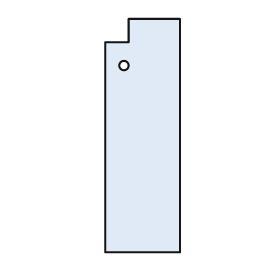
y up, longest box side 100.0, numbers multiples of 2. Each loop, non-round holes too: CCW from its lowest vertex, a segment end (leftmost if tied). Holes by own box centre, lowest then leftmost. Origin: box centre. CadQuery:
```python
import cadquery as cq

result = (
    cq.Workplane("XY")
    .moveTo(-16.0, -50.0)
    .lineTo(16.0, -50.0)
    .lineTo(16.0, 50.0)
    .lineTo(-6.0, 50.0)
    .lineTo(-6.0, 40.0)
    .lineTo(-16.0, 40.0)
    .close()
    .moveTo(-8.0, 30.0)
    .circle(2.0)
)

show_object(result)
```